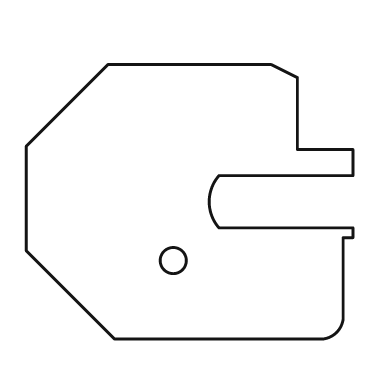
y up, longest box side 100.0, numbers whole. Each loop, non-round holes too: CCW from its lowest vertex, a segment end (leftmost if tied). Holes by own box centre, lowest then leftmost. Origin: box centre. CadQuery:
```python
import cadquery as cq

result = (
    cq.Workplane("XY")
    .moveTo(-23.0, -42.0)
    .lineTo(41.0, -42.0)
    .threePointArc((45.0, -40.0), (47.0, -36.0))
    .lineTo(47.0, -11.0)
    .lineTo(50.0, -11.0)
    .lineTo(50.0, -8.0)
    .lineTo(9.0, -8.0)
    .threePointArc((6.0, 0.0), (9.0, 8.0))
    .lineTo(50.0, 8.0)
    .lineTo(50.0, 16.0)
    .lineTo(33.0, 16.0)
    .lineTo(33.0, 38.0)
    .lineTo(25.0, 42.0)
    .lineTo(-25.0, 42.0)
    .lineTo(-50.0, 17.0)
    .lineTo(-50.0, -15.0)
    .close()
    .moveTo(-5.0, -18.0)
    .circle(4.0)
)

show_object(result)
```